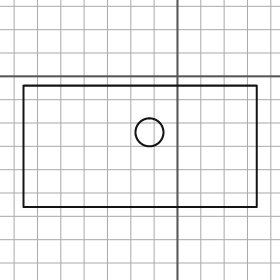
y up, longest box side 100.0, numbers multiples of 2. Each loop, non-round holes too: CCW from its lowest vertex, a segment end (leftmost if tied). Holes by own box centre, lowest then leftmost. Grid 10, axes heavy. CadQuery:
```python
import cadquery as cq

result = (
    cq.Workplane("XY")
    .moveTo(-66.0, -56.0)
    .lineTo(34.0, -56.0)
    .lineTo(34.0, -4.0)
    .lineTo(-66.0, -4.0)
    .close()
    .moveTo(-12.0, -24.0)
    .circle(6.0)
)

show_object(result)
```